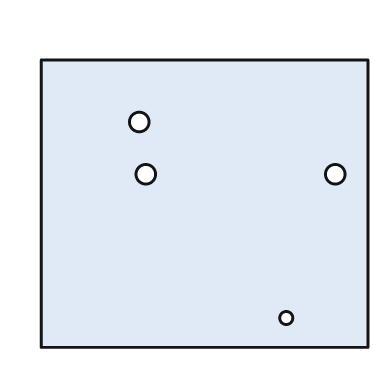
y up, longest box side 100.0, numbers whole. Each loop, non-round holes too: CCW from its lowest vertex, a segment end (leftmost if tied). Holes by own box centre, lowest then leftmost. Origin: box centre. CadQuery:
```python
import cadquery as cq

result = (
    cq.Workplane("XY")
    .moveTo(-50.0, -44.0)
    .lineTo(50.0, -44.0)
    .lineTo(50.0, 44.0)
    .lineTo(-50.0, 44.0)
    .close()
    .moveTo(25.0, -35.0)
    .circle(2.0)
    .moveTo(-18.0, 9.0)
    .circle(3.0)
    .moveTo(40.0, 9.0)
    .circle(3.0)
    .moveTo(-20.0, 25.0)
    .circle(3.0)
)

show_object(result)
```